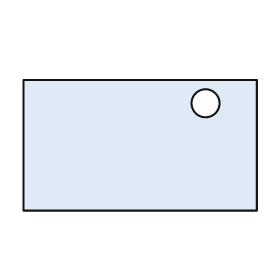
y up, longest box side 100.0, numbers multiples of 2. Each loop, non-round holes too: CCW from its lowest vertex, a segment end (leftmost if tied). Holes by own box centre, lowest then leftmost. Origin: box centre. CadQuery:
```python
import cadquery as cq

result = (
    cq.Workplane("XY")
    .moveTo(-50.0, -28.0)
    .lineTo(50.0, -28.0)
    .lineTo(50.0, 28.0)
    .lineTo(-50.0, 28.0)
    .close()
    .moveTo(28.0, 18.0)
    .circle(6.0)
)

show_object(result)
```